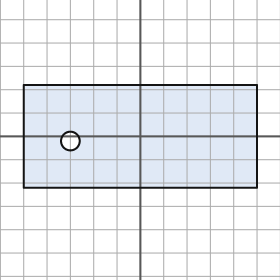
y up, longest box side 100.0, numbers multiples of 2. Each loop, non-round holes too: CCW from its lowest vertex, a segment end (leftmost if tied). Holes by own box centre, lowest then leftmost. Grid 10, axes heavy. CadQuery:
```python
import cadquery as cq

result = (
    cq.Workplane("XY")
    .moveTo(-50.0, -22.0)
    .lineTo(50.0, -22.0)
    .lineTo(50.0, 22.0)
    .lineTo(-50.0, 22.0)
    .close()
    .moveTo(-30.0, -2.0)
    .circle(4.0)
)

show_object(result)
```